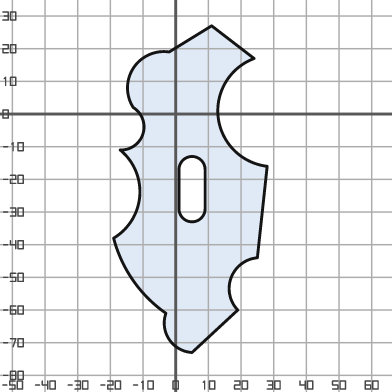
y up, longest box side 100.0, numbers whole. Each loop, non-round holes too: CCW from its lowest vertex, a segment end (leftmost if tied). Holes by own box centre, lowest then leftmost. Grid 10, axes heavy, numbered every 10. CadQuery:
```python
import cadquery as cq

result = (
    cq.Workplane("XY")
    .moveTo(5.0, -73.0)
    .lineTo(19.0, -60.0)
    .threePointArc((17.0, -50.0), (25.0, -44.0))
    .lineTo(28.0, -16.0)
    .threePointArc((13.0, -1.0), (24.0, 17.0))
    .lineTo(11.0, 27.0)
    .lineTo(-2.0, 19.0)
    .threePointArc((-13.0, 14.0), (-13.0, 2.0))
    .threePointArc((-10.0, -6.0), (-17.0, -11.0))
    .threePointArc((-11.0, -25.0), (-19.0, -38.0))
    .threePointArc((-13.0, -51.0), (-3.0, -61.0))
    .threePointArc((-2.0, -69.0), (5.0, -73.0))
    .close()
    .moveTo(1.0, -29.0)
    .threePointArc((5.0, -33.0), (9.0, -29.0))
    .lineTo(9.0, -17.0)
    .threePointArc((5.0, -13.0), (1.0, -17.0))
    .close()
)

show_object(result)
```